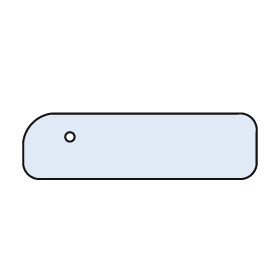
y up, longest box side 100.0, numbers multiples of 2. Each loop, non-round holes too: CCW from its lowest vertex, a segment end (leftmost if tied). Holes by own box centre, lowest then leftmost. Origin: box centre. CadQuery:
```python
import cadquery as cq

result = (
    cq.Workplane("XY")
    .moveTo(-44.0, -14.0)
    .lineTo(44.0, -14.0)
    .threePointArc((48.0, -12.0), (50.0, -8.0))
    .lineTo(50.0, 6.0)
    .threePointArc((48.0, 12.0), (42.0, 14.0))
    .lineTo(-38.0, 14.0)
    .threePointArc((-46.0, 10.0), (-50.0, 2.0))
    .lineTo(-50.0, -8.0)
    .threePointArc((-48.0, -12.0), (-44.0, -14.0))
    .close()
    .moveTo(-30.0, 4.0)
    .circle(2.0)
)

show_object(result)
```